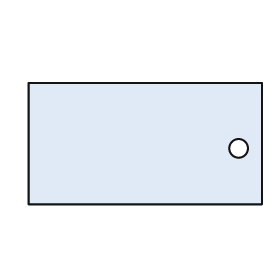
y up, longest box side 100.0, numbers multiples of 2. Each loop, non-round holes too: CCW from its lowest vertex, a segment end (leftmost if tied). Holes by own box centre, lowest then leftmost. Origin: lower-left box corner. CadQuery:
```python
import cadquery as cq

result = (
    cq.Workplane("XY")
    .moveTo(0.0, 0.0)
    .lineTo(100.0, 0.0)
    .lineTo(100.0, 52.0)
    .lineTo(0.0, 52.0)
    .close()
    .moveTo(90.0, 24.0)
    .circle(4.0)
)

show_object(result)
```